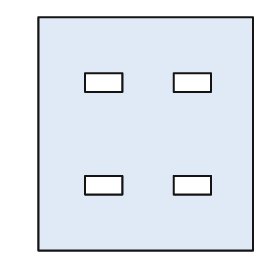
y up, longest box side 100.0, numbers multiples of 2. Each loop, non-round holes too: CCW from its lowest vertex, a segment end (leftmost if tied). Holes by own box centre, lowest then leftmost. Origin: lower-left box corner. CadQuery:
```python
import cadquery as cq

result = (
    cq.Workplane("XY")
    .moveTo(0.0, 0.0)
    .lineTo(92.0, 0.0)
    .lineTo(92.0, 100.0)
    .lineTo(0.0, 100.0)
    .close()
    .moveTo(20.0, 24.0)
    .lineTo(36.0, 24.0)
    .lineTo(36.0, 32.0)
    .lineTo(20.0, 32.0)
    .close()
    .moveTo(58.0, 24.0)
    .lineTo(74.0, 24.0)
    .lineTo(74.0, 32.0)
    .lineTo(58.0, 32.0)
    .close()
    .moveTo(20.0, 68.0)
    .lineTo(36.0, 68.0)
    .lineTo(36.0, 76.0)
    .lineTo(20.0, 76.0)
    .close()
    .moveTo(58.0, 68.0)
    .lineTo(74.0, 68.0)
    .lineTo(74.0, 76.0)
    .lineTo(58.0, 76.0)
    .close()
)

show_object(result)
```